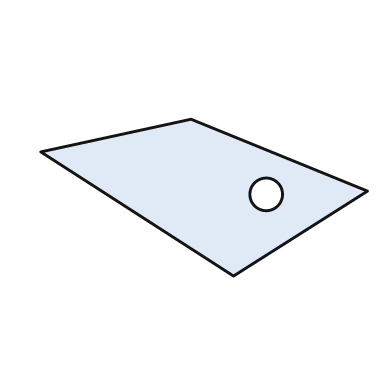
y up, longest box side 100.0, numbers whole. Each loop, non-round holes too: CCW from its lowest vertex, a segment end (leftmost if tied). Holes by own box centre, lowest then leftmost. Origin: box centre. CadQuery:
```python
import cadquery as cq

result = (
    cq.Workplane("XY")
    .moveTo(9.0, -24.0)
    .lineTo(50.0, 2.0)
    .lineTo(-4.0, 24.0)
    .lineTo(-50.0, 14.0)
    .close()
    .moveTo(19.0, 1.0)
    .circle(5.0)
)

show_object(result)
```